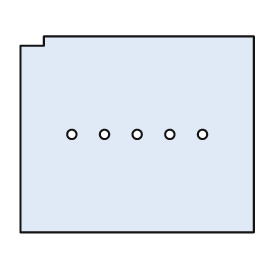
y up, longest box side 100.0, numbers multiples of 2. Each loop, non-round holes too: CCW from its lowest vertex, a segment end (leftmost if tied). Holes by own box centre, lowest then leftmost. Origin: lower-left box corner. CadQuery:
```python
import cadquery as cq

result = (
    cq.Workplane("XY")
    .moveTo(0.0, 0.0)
    .lineTo(100.0, 0.0)
    .lineTo(100.0, 84.0)
    .lineTo(10.0, 84.0)
    .lineTo(10.0, 80.0)
    .lineTo(0.0, 80.0)
    .close()
    .moveTo(22.0, 42.0)
    .circle(2.0)
    .moveTo(36.0, 42.0)
    .circle(2.0)
    .moveTo(50.0, 42.0)
    .circle(2.0)
    .moveTo(64.0, 42.0)
    .circle(2.0)
    .moveTo(78.0, 42.0)
    .circle(2.0)
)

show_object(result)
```